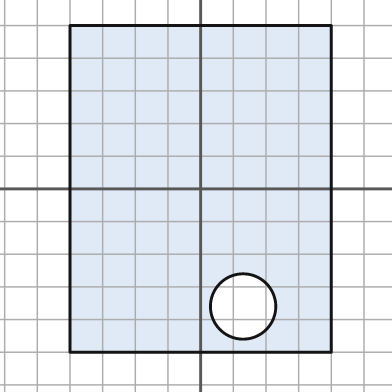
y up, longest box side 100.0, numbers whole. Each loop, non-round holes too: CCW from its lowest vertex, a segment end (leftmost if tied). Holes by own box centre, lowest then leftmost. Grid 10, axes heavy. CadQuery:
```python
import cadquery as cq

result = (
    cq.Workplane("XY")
    .moveTo(-40.0, -50.0)
    .lineTo(40.0, -50.0)
    .lineTo(40.0, 50.0)
    .lineTo(-40.0, 50.0)
    .close()
    .moveTo(13.0, -36.0)
    .circle(10.0)
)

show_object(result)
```